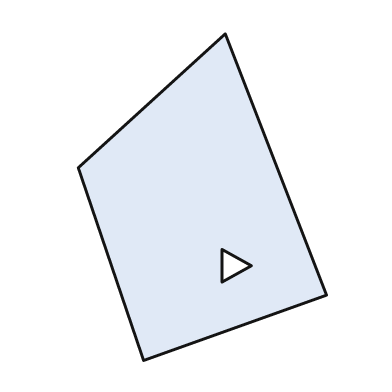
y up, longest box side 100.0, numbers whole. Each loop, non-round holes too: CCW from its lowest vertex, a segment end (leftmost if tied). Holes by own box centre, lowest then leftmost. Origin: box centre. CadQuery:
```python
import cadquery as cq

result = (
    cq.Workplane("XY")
    .moveTo(-18.0, -50.0)
    .lineTo(38.0, -30.0)
    .lineTo(7.0, 50.0)
    .lineTo(-38.0, 9.0)
    .close()
    .moveTo(6.0, -26.0)
    .lineTo(15.0, -21.0)
    .lineTo(6.0, -16.0)
    .close()
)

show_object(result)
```